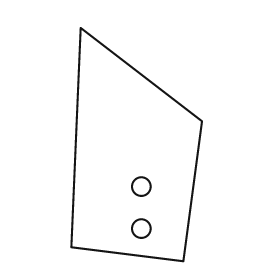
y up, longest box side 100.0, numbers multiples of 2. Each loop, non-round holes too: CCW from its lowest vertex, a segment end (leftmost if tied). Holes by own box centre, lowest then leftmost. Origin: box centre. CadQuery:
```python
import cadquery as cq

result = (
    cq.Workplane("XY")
    .moveTo(20.0, -50.0)
    .lineTo(28.0, 10.0)
    .lineTo(-24.0, 50.0)
    .lineTo(-28.0, -44.0)
    .close()
    .moveTo(2.0, -36.0)
    .circle(4.0)
    .moveTo(2.0, -18.0)
    .circle(4.0)
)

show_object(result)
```